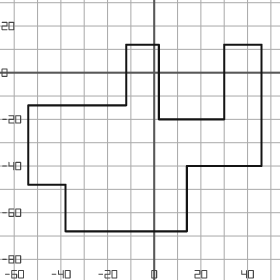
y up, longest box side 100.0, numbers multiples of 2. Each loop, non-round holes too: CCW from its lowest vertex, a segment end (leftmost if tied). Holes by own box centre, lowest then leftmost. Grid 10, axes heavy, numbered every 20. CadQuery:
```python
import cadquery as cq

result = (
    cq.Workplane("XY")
    .moveTo(-38.0, -68.0)
    .lineTo(14.0, -68.0)
    .lineTo(14.0, -40.0)
    .lineTo(46.0, -40.0)
    .lineTo(46.0, 12.0)
    .lineTo(30.0, 12.0)
    .lineTo(30.0, -20.0)
    .lineTo(2.0, -20.0)
    .lineTo(2.0, 12.0)
    .lineTo(-12.0, 12.0)
    .lineTo(-12.0, -14.0)
    .lineTo(-54.0, -14.0)
    .lineTo(-54.0, -48.0)
    .lineTo(-38.0, -48.0)
    .close()
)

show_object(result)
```